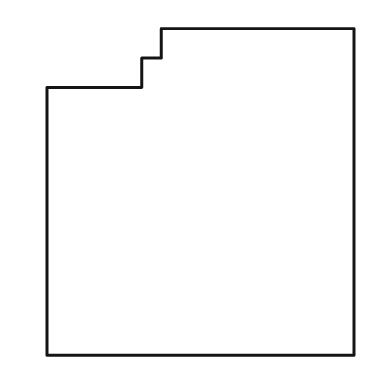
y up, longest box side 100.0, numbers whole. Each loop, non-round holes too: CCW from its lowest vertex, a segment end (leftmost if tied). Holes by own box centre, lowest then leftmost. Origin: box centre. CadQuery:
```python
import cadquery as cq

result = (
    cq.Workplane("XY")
    .moveTo(-47.0, -50.0)
    .lineTo(47.0, -50.0)
    .lineTo(47.0, 50.0)
    .lineTo(-12.0, 50.0)
    .lineTo(-12.0, 41.0)
    .lineTo(-18.0, 41.0)
    .lineTo(-18.0, 32.0)
    .lineTo(-47.0, 32.0)
    .close()
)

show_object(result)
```